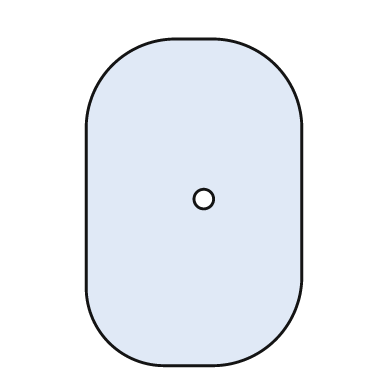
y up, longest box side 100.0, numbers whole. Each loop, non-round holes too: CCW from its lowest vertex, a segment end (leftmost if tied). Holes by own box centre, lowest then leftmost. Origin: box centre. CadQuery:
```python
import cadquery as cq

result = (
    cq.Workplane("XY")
    .moveTo(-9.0, -50.0)
    .lineTo(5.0, -50.0)
    .threePointArc((25.0, -42.0), (33.0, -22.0))
    .lineTo(33.0, 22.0)
    .threePointArc((25.0, 42.0), (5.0, 50.0))
    .lineTo(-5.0, 50.0)
    .threePointArc((-25.0, 42.0), (-33.0, 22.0))
    .lineTo(-33.0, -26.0)
    .threePointArc((-26.0, -43.0), (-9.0, -50.0))
    .close()
    .moveTo(3.0, 1.0)
    .circle(3.0)
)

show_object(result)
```